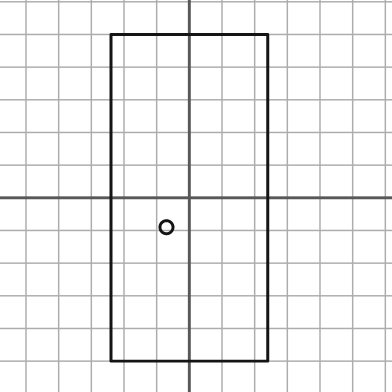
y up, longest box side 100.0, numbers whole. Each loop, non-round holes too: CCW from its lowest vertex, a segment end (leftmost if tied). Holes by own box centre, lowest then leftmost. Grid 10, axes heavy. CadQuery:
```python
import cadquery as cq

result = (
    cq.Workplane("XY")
    .moveTo(-24.0, -50.0)
    .lineTo(24.0, -50.0)
    .lineTo(24.0, 50.0)
    .lineTo(-24.0, 50.0)
    .close()
    .moveTo(-7.0, -9.0)
    .circle(2.0)
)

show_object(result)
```